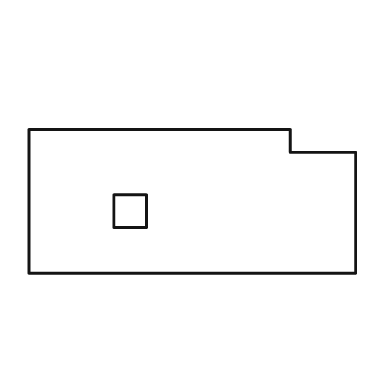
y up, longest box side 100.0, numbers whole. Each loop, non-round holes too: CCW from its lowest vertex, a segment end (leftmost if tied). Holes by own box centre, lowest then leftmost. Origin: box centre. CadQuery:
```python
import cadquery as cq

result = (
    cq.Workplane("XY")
    .moveTo(-50.0, -22.0)
    .lineTo(50.0, -22.0)
    .lineTo(50.0, 15.0)
    .lineTo(30.0, 15.0)
    .lineTo(30.0, 22.0)
    .lineTo(-50.0, 22.0)
    .close()
    .moveTo(-24.0, -8.0)
    .lineTo(-14.0, -8.0)
    .lineTo(-14.0, 2.0)
    .lineTo(-24.0, 2.0)
    .close()
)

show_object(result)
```